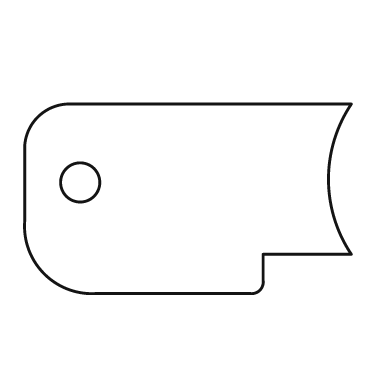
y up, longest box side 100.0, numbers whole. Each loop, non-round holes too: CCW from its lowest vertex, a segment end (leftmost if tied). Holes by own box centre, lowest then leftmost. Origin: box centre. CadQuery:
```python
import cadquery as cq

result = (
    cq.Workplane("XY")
    .moveTo(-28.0, -29.0)
    .lineTo(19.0, -29.0)
    .threePointArc((22.0, -28.0), (23.0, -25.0))
    .lineTo(23.0, -17.0)
    .lineTo(50.0, -17.0)
    .threePointArc((43.0, 6.0), (50.0, 29.0))
    .lineTo(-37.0, 29.0)
    .threePointArc((-46.0, 25.0), (-50.0, 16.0))
    .lineTo(-50.0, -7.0)
    .threePointArc((-44.0, -23.0), (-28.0, -29.0))
    .close()
    .moveTo(-33.0, 5.0)
    .circle(6.0)
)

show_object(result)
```